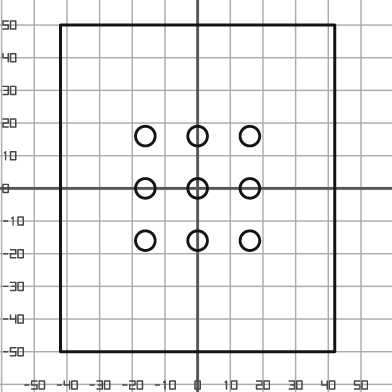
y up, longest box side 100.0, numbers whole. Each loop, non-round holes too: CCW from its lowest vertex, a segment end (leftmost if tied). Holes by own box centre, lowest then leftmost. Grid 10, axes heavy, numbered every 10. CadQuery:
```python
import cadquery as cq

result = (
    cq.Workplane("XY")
    .moveTo(-42.0, -50.0)
    .lineTo(42.0, -50.0)
    .lineTo(42.0, 50.0)
    .lineTo(-42.0, 50.0)
    .close()
    .moveTo(-16.0, -16.0)
    .circle(3.0)
    .moveTo(0.0, -16.0)
    .circle(3.0)
    .moveTo(16.0, -16.0)
    .circle(3.0)
    .moveTo(-16.0, 0.0)
    .circle(3.0)
    .moveTo(0.0, 0.0)
    .circle(3.0)
    .moveTo(16.0, 0.0)
    .circle(3.0)
    .moveTo(-16.0, 16.0)
    .circle(3.0)
    .moveTo(0.0, 16.0)
    .circle(3.0)
    .moveTo(16.0, 16.0)
    .circle(3.0)
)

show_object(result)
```